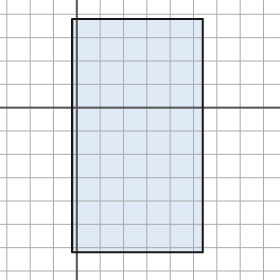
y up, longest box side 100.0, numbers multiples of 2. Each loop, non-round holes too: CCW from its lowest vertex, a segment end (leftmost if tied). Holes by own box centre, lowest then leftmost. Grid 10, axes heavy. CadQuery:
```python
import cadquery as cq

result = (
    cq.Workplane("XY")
    .moveTo(-2.0, -62.0)
    .lineTo(54.0, -62.0)
    .lineTo(54.0, 38.0)
    .lineTo(-2.0, 38.0)
    .close()
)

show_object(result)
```